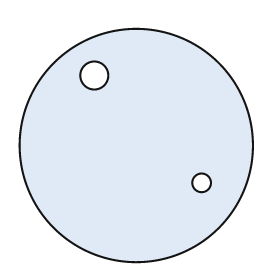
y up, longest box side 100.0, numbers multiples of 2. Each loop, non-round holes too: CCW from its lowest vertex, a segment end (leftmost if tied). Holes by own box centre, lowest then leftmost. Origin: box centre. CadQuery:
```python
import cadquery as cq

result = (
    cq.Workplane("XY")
    .moveTo(0.0, 0.0)
    .circle(50.0)
    .moveTo(28.0, -16.0)
    .circle(4.0)
    .moveTo(-18.0, 30.0)
    .circle(6.0)
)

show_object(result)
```